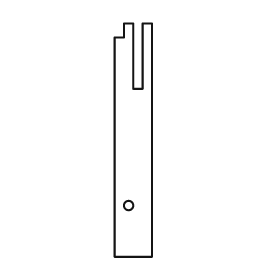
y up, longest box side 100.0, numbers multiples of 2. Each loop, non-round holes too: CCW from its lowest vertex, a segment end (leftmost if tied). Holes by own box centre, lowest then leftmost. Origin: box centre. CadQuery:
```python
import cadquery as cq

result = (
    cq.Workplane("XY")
    .moveTo(-8.0, -50.0)
    .lineTo(8.0, -50.0)
    .lineTo(8.0, 50.0)
    .lineTo(4.0, 50.0)
    .lineTo(4.0, 22.0)
    .lineTo(0.0, 22.0)
    .lineTo(0.0, 50.0)
    .lineTo(-4.0, 50.0)
    .lineTo(-4.0, 44.0)
    .lineTo(-8.0, 44.0)
    .close()
    .moveTo(-2.0, -28.0)
    .circle(2.0)
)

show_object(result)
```